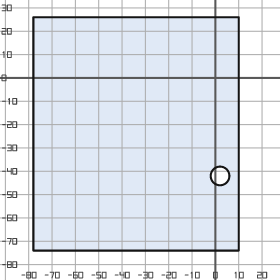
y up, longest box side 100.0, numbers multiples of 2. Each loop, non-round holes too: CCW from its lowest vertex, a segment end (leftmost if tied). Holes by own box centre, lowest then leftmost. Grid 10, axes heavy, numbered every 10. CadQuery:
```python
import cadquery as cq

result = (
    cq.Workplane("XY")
    .moveTo(-78.0, -74.0)
    .lineTo(10.0, -74.0)
    .lineTo(10.0, 26.0)
    .lineTo(-78.0, 26.0)
    .close()
    .moveTo(2.0, -42.0)
    .circle(4.0)
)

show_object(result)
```